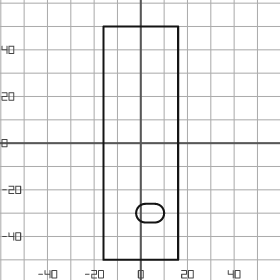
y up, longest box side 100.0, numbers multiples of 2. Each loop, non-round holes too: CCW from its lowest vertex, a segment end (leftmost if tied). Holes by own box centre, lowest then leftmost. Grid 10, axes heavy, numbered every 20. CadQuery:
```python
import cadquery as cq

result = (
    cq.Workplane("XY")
    .moveTo(-16.0, -50.0)
    .lineTo(16.0, -50.0)
    .lineTo(16.0, 50.0)
    .lineTo(-16.0, 50.0)
    .close()
    .moveTo(2.0, -34.0)
    .lineTo(6.0, -34.0)
    .threePointArc((10.0, -30.0), (6.0, -26.0))
    .lineTo(2.0, -26.0)
    .threePointArc((-2.0, -30.0), (2.0, -34.0))
    .close()
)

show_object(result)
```